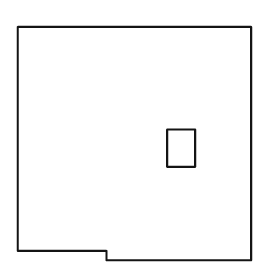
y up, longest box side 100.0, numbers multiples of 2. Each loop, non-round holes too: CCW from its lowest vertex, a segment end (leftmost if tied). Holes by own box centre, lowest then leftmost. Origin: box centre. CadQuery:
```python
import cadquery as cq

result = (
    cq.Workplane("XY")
    .moveTo(-12.0, -50.0)
    .lineTo(50.0, -50.0)
    .lineTo(50.0, 50.0)
    .lineTo(-50.0, 50.0)
    .lineTo(-50.0, -46.0)
    .lineTo(-12.0, -46.0)
    .close()
    .moveTo(14.0, -10.0)
    .lineTo(26.0, -10.0)
    .lineTo(26.0, 6.0)
    .lineTo(14.0, 6.0)
    .close()
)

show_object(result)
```